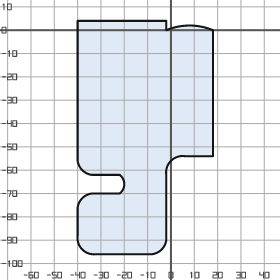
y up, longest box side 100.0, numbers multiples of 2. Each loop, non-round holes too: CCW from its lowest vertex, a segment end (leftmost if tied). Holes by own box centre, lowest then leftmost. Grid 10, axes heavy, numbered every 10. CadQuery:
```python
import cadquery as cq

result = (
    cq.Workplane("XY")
    .moveTo(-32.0, -96.0)
    .lineTo(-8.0, -96.0)
    .threePointArc((-4.0, -94.0), (-2.0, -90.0))
    .lineTo(-2.0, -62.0)
    .threePointArc((0.0, -56.0), (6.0, -54.0))
    .lineTo(18.0, -54.0)
    .lineTo(18.0, 0.0)
    .threePointArc((8.0, 2.0), (-2.0, 0.0))
    .lineTo(-2.0, 4.0)
    .lineTo(-40.0, 4.0)
    .lineTo(-40.0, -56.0)
    .threePointArc((-38.0, -60.0), (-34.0, -62.0))
    .lineTo(-22.0, -62.0)
    .threePointArc((-20.0, -66.0), (-22.0, -70.0))
    .lineTo(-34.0, -70.0)
    .threePointArc((-38.0, -72.0), (-40.0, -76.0))
    .lineTo(-40.0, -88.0)
    .threePointArc((-38.0, -94.0), (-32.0, -96.0))
    .close()
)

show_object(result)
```